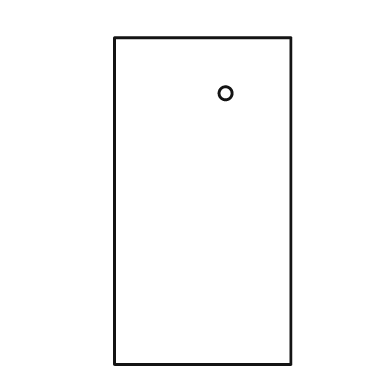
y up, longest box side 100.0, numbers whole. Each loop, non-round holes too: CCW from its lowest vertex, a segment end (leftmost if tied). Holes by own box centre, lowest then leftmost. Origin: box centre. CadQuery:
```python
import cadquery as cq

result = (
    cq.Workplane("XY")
    .moveTo(-27.0, -50.0)
    .lineTo(27.0, -50.0)
    .lineTo(27.0, 50.0)
    .lineTo(-27.0, 50.0)
    .close()
    .moveTo(7.0, 33.0)
    .circle(2.0)
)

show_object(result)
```